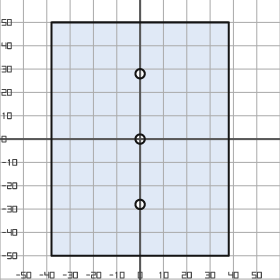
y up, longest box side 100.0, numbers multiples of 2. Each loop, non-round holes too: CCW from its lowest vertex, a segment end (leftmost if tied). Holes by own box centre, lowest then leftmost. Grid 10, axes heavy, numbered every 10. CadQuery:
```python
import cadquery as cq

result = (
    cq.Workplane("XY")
    .moveTo(-38.0, -50.0)
    .lineTo(38.0, -50.0)
    .lineTo(38.0, 50.0)
    .lineTo(-38.0, 50.0)
    .close()
    .moveTo(0.0, -28.0)
    .circle(2.0)
    .moveTo(0.0, 0.0)
    .circle(2.0)
    .moveTo(0.0, 28.0)
    .circle(2.0)
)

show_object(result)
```